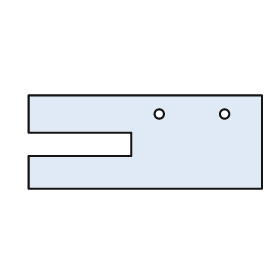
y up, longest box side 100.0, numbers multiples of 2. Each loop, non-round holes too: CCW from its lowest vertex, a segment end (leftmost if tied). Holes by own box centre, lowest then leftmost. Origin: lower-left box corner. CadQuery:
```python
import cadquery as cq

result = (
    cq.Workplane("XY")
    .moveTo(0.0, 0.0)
    .lineTo(100.0, 0.0)
    .lineTo(100.0, 40.0)
    .lineTo(0.0, 40.0)
    .lineTo(0.0, 24.0)
    .lineTo(44.0, 24.0)
    .lineTo(44.0, 14.0)
    .lineTo(0.0, 14.0)
    .close()
    .moveTo(56.0, 32.0)
    .circle(2.0)
    .moveTo(84.0, 32.0)
    .circle(2.0)
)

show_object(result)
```